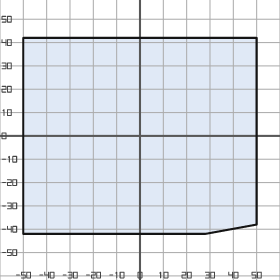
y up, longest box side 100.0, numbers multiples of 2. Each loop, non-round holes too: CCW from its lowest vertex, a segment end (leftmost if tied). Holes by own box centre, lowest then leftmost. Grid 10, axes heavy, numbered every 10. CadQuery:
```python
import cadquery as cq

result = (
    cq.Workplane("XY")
    .moveTo(-50.0, -42.0)
    .lineTo(28.0, -42.0)
    .lineTo(50.0, -38.0)
    .lineTo(50.0, 42.0)
    .lineTo(-50.0, 42.0)
    .close()
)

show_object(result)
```